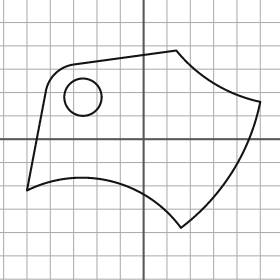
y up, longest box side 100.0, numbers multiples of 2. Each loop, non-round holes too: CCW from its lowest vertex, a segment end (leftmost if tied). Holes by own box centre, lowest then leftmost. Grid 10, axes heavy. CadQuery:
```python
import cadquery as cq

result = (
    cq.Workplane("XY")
    .moveTo(16.0, -38.0)
    .threePointArc((38.0, -14.0), (50.0, 16.0))
    .threePointArc((30.0, 24.0), (14.0, 38.0))
    .lineTo(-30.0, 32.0)
    .threePointArc((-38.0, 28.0), (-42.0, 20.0))
    .lineTo(-50.0, -22.0)
    .threePointArc((-14.0, -18.0), (16.0, -38.0))
    .close()
    .moveTo(-26.0, 18.0)
    .circle(8.0)
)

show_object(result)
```